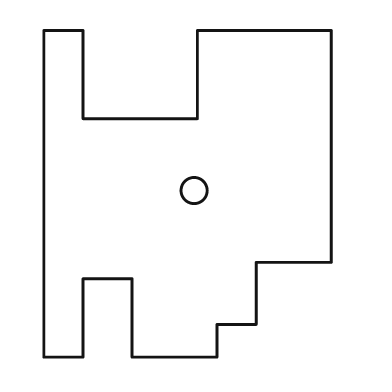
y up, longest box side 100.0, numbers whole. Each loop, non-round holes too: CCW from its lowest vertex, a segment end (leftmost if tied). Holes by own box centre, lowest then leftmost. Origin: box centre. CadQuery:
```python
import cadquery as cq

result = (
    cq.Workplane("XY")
    .moveTo(-44.0, -50.0)
    .lineTo(-32.0, -50.0)
    .lineTo(-32.0, -26.0)
    .lineTo(-17.0, -26.0)
    .lineTo(-17.0, -50.0)
    .lineTo(9.0, -50.0)
    .lineTo(9.0, -40.0)
    .lineTo(21.0, -40.0)
    .lineTo(21.0, -21.0)
    .lineTo(44.0, -21.0)
    .lineTo(44.0, 50.0)
    .lineTo(3.0, 50.0)
    .lineTo(3.0, 23.0)
    .lineTo(-32.0, 23.0)
    .lineTo(-32.0, 50.0)
    .lineTo(-44.0, 50.0)
    .close()
    .moveTo(2.0, 1.0)
    .circle(4.0)
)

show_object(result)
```